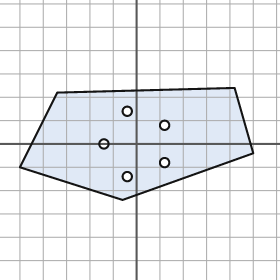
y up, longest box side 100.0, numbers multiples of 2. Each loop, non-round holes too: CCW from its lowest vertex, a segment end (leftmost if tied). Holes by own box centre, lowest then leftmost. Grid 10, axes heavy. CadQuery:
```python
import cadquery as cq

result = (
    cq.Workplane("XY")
    .moveTo(-6.0, -24.0)
    .lineTo(50.0, -4.0)
    .lineTo(42.0, 24.0)
    .lineTo(-34.0, 22.0)
    .lineTo(-50.0, -10.0)
    .close()
    .moveTo(-4.0, -14.0)
    .circle(2.0)
    .moveTo(12.0, -8.0)
    .circle(2.0)
    .moveTo(-14.0, 0.0)
    .circle(2.0)
    .moveTo(12.0, 8.0)
    .circle(2.0)
    .moveTo(-4.0, 14.0)
    .circle(2.0)
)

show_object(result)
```